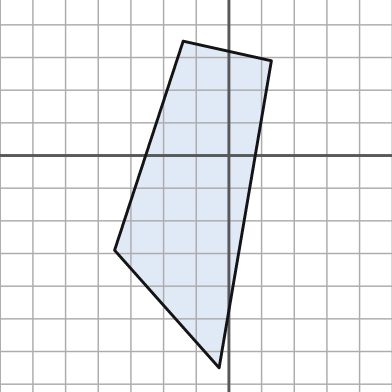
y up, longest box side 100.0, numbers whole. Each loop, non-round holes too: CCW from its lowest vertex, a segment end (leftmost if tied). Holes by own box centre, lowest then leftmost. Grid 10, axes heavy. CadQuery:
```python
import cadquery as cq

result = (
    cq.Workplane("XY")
    .moveTo(-3.0, -65.0)
    .lineTo(13.0, 29.0)
    .lineTo(-14.0, 35.0)
    .lineTo(-35.0, -29.0)
    .close()
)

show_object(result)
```